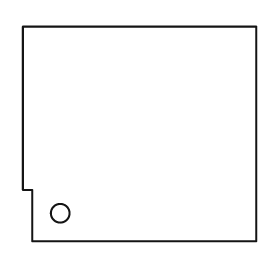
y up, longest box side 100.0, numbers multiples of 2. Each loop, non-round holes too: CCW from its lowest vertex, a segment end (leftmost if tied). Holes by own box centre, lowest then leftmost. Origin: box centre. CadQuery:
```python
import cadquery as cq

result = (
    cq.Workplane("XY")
    .moveTo(-46.0, -46.0)
    .lineTo(50.0, -46.0)
    .lineTo(50.0, 46.0)
    .lineTo(-50.0, 46.0)
    .lineTo(-50.0, -24.0)
    .lineTo(-46.0, -24.0)
    .close()
    .moveTo(-34.0, -34.0)
    .circle(4.0)
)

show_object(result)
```